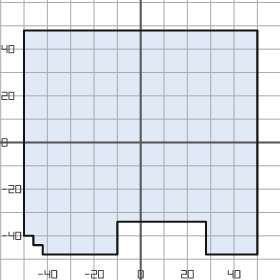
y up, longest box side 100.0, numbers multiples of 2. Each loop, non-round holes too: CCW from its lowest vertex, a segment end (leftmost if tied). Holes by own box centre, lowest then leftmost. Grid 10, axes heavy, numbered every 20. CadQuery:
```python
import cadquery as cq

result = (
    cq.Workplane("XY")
    .moveTo(-42.0, -48.0)
    .lineTo(-10.0, -48.0)
    .lineTo(-10.0, -34.0)
    .lineTo(28.0, -34.0)
    .lineTo(28.0, -48.0)
    .lineTo(50.0, -48.0)
    .lineTo(50.0, 48.0)
    .lineTo(-50.0, 48.0)
    .lineTo(-50.0, -40.0)
    .lineTo(-46.0, -40.0)
    .lineTo(-46.0, -44.0)
    .lineTo(-42.0, -44.0)
    .close()
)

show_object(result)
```